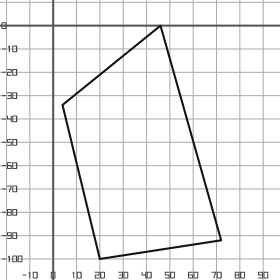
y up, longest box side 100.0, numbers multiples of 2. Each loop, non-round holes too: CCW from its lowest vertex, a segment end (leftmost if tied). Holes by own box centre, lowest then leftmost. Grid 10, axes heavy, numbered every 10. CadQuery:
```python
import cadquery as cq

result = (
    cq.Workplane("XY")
    .moveTo(20.0, -100.0)
    .lineTo(72.0, -92.0)
    .lineTo(46.0, 0.0)
    .lineTo(4.0, -34.0)
    .close()
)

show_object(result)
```